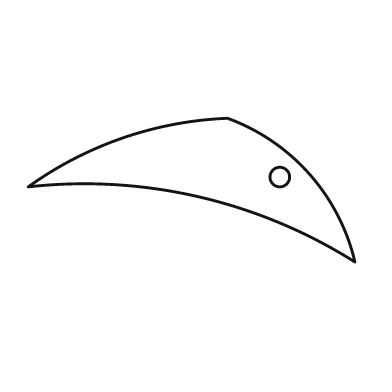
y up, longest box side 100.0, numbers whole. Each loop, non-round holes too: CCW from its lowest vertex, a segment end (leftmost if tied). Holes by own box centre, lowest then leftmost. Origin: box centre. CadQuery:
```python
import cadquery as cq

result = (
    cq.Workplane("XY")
    .moveTo(50.0, -22.0)
    .threePointArc((36.0, 5.0), (11.0, 22.0))
    .threePointArc((-21.0, 16.0), (-50.0, 1.0))
    .threePointArc((2.0, -2.0), (50.0, -22.0))
    .close()
    .moveTo(27.0, 4.0)
    .circle(3.0)
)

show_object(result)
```